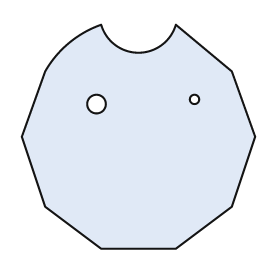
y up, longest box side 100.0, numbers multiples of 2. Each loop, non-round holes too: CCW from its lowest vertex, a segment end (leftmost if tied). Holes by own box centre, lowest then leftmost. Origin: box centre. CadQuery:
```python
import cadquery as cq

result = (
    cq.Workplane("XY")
    .moveTo(-16.0, -48.0)
    .lineTo(16.0, -48.0)
    .lineTo(40.0, -30.0)
    .lineTo(50.0, 0.0)
    .lineTo(40.0, 28.0)
    .lineTo(16.0, 48.0)
    .threePointArc((0.0, 36.0), (-16.0, 48.0))
    .threePointArc((-30.0, 40.0), (-40.0, 28.0))
    .lineTo(-50.0, 0.0)
    .lineTo(-40.0, -30.0)
    .close()
    .moveTo(-18.0, 14.0)
    .circle(4.0)
    .moveTo(24.0, 16.0)
    .circle(2.0)
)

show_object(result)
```